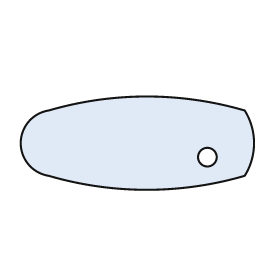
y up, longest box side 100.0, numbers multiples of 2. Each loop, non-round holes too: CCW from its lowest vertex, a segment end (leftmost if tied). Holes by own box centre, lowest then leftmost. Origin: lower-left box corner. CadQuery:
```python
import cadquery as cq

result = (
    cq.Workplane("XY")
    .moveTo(12.0, 6.0)
    .threePointArc((54.0, 0.0), (96.0, 6.0))
    .threePointArc((100.0, 20.0), (96.0, 34.0))
    .threePointArc((54.0, 40.0), (12.0, 34.0))
    .threePointArc((0.0, 20.0), (12.0, 6.0))
    .close()
    .moveTo(80.0, 14.0)
    .circle(4.0)
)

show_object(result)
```